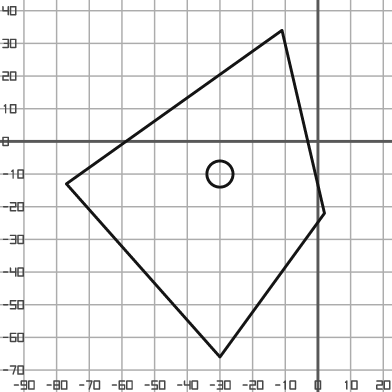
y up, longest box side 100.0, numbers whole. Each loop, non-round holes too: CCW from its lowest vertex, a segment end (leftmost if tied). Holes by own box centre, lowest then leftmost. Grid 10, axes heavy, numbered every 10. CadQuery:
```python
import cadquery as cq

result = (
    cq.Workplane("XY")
    .moveTo(-30.0, -66.0)
    .lineTo(2.0, -22.0)
    .lineTo(-11.0, 34.0)
    .lineTo(-77.0, -13.0)
    .close()
    .moveTo(-30.0, -10.0)
    .circle(4.0)
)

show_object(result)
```